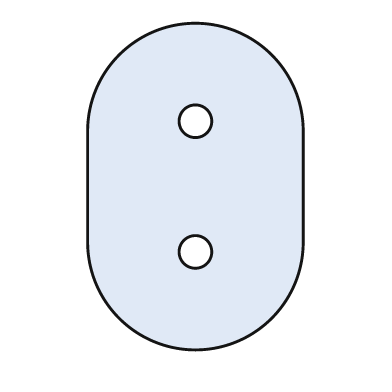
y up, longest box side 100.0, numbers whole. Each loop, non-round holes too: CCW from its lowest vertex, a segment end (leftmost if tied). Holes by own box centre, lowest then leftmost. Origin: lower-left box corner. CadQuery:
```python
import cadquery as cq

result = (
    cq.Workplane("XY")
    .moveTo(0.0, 33.0)
    .threePointArc((33.0, 0.0), (66.0, 33.0))
    .lineTo(66.0, 67.0)
    .threePointArc((33.0, 100.0), (0.0, 67.0))
    .close()
    .moveTo(33.0, 30.0)
    .circle(5.0)
    .moveTo(33.0, 70.0)
    .circle(5.0)
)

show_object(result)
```